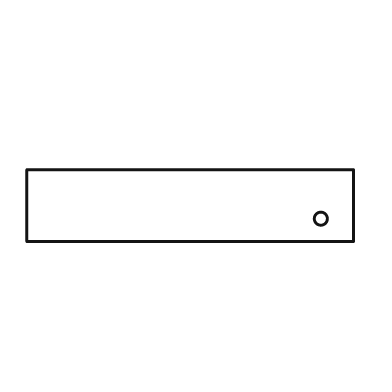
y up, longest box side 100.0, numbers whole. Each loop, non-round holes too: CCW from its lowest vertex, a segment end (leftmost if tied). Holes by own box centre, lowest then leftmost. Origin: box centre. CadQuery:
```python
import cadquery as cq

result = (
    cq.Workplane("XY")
    .moveTo(-50.0, -11.0)
    .lineTo(50.0, -11.0)
    .lineTo(50.0, 11.0)
    .lineTo(-50.0, 11.0)
    .close()
    .moveTo(40.0, -4.0)
    .circle(2.0)
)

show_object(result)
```